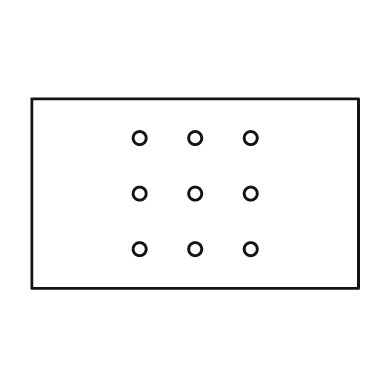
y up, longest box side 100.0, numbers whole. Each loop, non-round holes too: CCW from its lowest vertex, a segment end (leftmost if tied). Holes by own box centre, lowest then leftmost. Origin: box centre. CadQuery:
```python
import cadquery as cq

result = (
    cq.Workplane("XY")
    .moveTo(-50.0, -29.0)
    .lineTo(50.0, -29.0)
    .lineTo(50.0, 29.0)
    .lineTo(-50.0, 29.0)
    .close()
    .moveTo(-17.0, -17.0)
    .circle(2.0)
    .moveTo(0.0, -17.0)
    .circle(2.0)
    .moveTo(17.0, -17.0)
    .circle(2.0)
    .moveTo(-17.0, 0.0)
    .circle(2.0)
    .moveTo(0.0, 0.0)
    .circle(2.0)
    .moveTo(17.0, 0.0)
    .circle(2.0)
    .moveTo(-17.0, 17.0)
    .circle(2.0)
    .moveTo(0.0, 17.0)
    .circle(2.0)
    .moveTo(17.0, 17.0)
    .circle(2.0)
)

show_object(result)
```